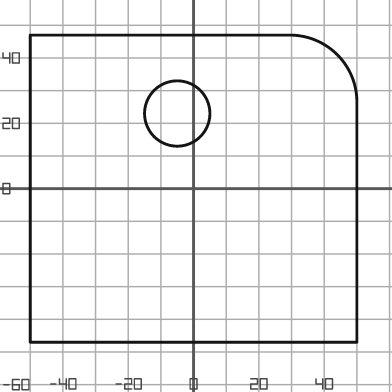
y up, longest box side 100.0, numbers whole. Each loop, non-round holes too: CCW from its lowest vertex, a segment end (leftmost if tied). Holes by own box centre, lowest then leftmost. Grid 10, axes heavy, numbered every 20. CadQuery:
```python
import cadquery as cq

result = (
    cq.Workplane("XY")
    .moveTo(-50.0, -47.0)
    .lineTo(50.0, -47.0)
    .lineTo(50.0, 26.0)
    .threePointArc((44.0, 41.0), (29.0, 47.0))
    .lineTo(-50.0, 47.0)
    .close()
    .moveTo(-5.0, 23.0)
    .circle(10.0)
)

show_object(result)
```